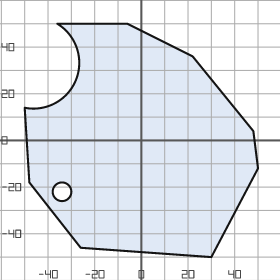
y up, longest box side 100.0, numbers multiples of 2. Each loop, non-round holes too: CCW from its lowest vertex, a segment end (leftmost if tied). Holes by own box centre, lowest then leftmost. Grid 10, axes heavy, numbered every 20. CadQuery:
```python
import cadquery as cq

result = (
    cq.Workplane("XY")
    .moveTo(30.0, -50.0)
    .lineTo(50.0, -12.0)
    .lineTo(48.0, 4.0)
    .lineTo(22.0, 36.0)
    .lineTo(-6.0, 50.0)
    .lineTo(-36.0, 50.0)
    .threePointArc((-28.0, 26.0), (-50.0, 14.0))
    .lineTo(-48.0, -18.0)
    .lineTo(-26.0, -46.0)
    .close()
    .moveTo(-34.0, -22.0)
    .circle(4.0)
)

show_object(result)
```